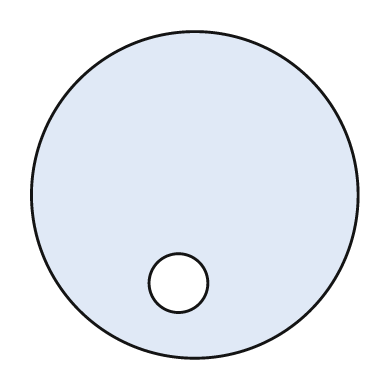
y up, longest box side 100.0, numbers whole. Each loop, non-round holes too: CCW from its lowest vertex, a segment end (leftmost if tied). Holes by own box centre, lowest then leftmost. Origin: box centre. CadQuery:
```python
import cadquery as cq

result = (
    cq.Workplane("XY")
    .moveTo(0.0, 0.0)
    .circle(50.0)
    .moveTo(-5.0, -27.0)
    .circle(9.0)
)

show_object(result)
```